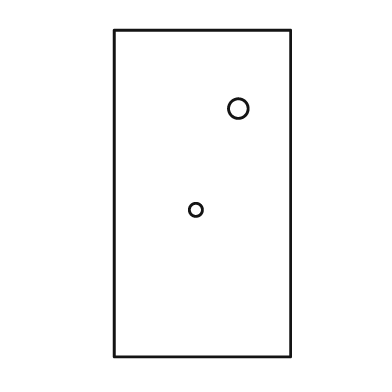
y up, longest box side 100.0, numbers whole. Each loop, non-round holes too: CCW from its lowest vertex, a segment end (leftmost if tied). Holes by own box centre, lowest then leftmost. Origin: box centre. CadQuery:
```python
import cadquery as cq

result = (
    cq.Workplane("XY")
    .moveTo(-27.0, -50.0)
    .lineTo(27.0, -50.0)
    .lineTo(27.0, 50.0)
    .lineTo(-27.0, 50.0)
    .close()
    .moveTo(-2.0, -5.0)
    .circle(2.0)
    .moveTo(11.0, 26.0)
    .circle(3.0)
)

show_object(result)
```